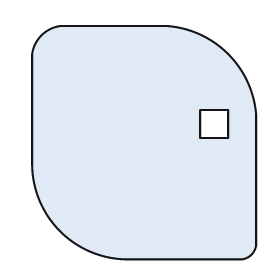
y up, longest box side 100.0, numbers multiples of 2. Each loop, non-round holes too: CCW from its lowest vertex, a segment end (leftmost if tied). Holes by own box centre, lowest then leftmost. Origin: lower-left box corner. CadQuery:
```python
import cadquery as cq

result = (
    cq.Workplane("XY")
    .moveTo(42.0, 0.0)
    .lineTo(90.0, 0.0)
    .threePointArc((94.0, 2.0), (96.0, 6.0))
    .lineTo(96.0, 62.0)
    .threePointArc((84.0, 88.0), (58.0, 100.0))
    .lineTo(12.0, 100.0)
    .threePointArc((4.0, 96.0), (0.0, 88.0))
    .lineTo(0.0, 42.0)
    .threePointArc((12.0, 12.0), (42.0, 0.0))
    .close()
    .moveTo(72.0, 52.0)
    .lineTo(84.0, 52.0)
    .lineTo(84.0, 64.0)
    .lineTo(72.0, 64.0)
    .close()
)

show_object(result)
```